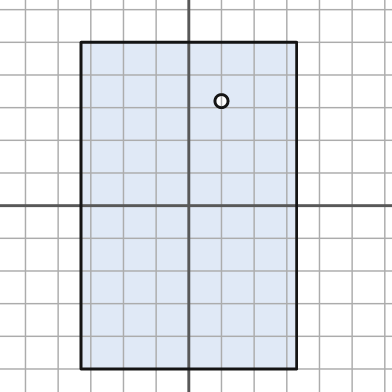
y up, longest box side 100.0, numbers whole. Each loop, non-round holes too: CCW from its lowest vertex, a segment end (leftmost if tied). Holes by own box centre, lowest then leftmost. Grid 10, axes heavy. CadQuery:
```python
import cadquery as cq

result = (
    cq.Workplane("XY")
    .moveTo(-33.0, -50.0)
    .lineTo(33.0, -50.0)
    .lineTo(33.0, 50.0)
    .lineTo(-33.0, 50.0)
    .close()
    .moveTo(10.0, 32.0)
    .circle(2.0)
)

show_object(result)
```